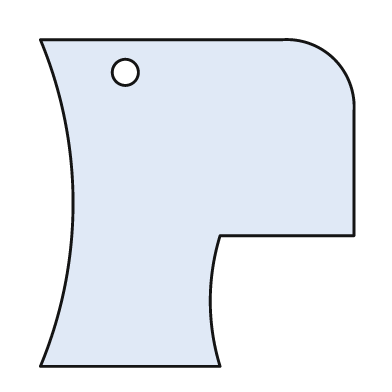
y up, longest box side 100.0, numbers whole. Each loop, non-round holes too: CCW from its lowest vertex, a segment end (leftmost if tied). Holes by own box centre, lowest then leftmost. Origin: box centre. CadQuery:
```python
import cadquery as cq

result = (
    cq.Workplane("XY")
    .moveTo(-48.0, -50.0)
    .lineTo(7.0, -50.0)
    .threePointArc((4.0, -30.0), (7.0, -10.0))
    .lineTo(48.0, -10.0)
    .lineTo(48.0, 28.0)
    .threePointArc((42.0, 44.0), (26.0, 50.0))
    .lineTo(-48.0, 50.0)
    .threePointArc((-38.0, 0.0), (-48.0, -50.0))
    .close()
    .moveTo(-22.0, 40.0)
    .circle(4.0)
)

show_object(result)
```